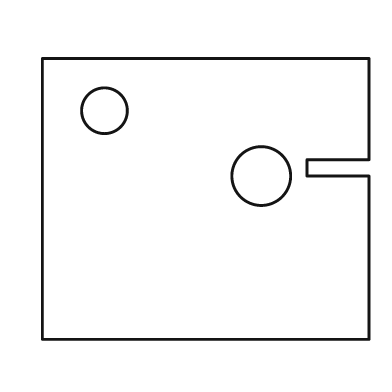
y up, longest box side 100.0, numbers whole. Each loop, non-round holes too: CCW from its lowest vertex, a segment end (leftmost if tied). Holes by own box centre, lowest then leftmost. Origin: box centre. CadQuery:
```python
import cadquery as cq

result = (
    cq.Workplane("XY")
    .moveTo(-50.0, -43.0)
    .lineTo(50.0, -43.0)
    .lineTo(50.0, 7.0)
    .lineTo(31.0, 7.0)
    .lineTo(31.0, 12.0)
    .lineTo(50.0, 12.0)
    .lineTo(50.0, 43.0)
    .lineTo(-50.0, 43.0)
    .close()
    .moveTo(17.0, 7.0)
    .circle(9.0)
    .moveTo(-31.0, 27.0)
    .circle(7.0)
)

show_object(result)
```